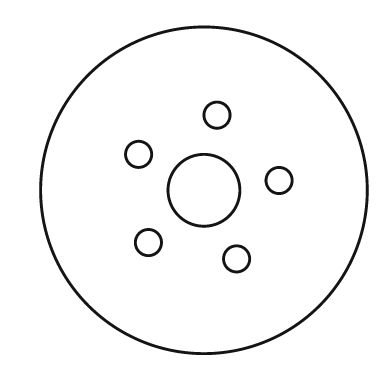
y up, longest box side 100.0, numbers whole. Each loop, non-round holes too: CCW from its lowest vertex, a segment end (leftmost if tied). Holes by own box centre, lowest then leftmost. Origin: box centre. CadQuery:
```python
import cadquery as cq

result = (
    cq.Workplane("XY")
    .moveTo(0.0, 0.0)
    .circle(50.0)
    .moveTo(10.0, -21.0)
    .circle(4.0)
    .moveTo(-17.0, -16.0)
    .circle(4.0)
    .moveTo(0.0, 0.0)
    .circle(11.0)
    .moveTo(23.0, 3.0)
    .circle(4.0)
    .moveTo(-20.0, 11.0)
    .circle(4.0)
    .moveTo(4.0, 23.0)
    .circle(4.0)
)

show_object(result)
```